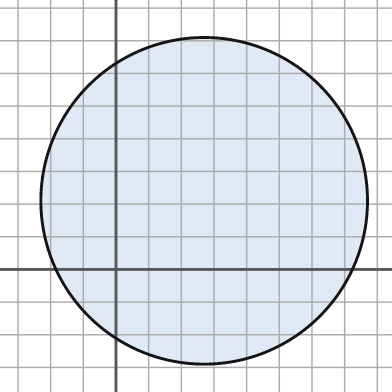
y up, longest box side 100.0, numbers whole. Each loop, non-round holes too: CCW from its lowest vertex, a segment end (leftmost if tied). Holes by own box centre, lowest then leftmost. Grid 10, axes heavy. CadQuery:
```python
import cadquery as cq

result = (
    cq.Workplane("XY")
    .moveTo(27.0, 21.0)
    .circle(50.0)
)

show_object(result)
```